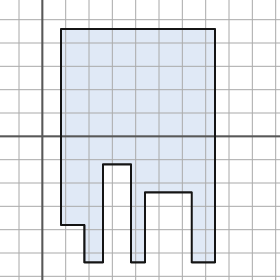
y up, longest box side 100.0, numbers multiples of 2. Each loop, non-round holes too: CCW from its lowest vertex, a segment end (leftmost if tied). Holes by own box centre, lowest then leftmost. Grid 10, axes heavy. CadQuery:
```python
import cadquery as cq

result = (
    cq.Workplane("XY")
    .moveTo(18.0, -54.0)
    .lineTo(26.0, -54.0)
    .lineTo(26.0, -12.0)
    .lineTo(38.0, -12.0)
    .lineTo(38.0, -54.0)
    .lineTo(44.0, -54.0)
    .lineTo(44.0, -24.0)
    .lineTo(64.0, -24.0)
    .lineTo(64.0, -54.0)
    .lineTo(74.0, -54.0)
    .lineTo(74.0, 46.0)
    .lineTo(8.0, 46.0)
    .lineTo(8.0, -38.0)
    .lineTo(18.0, -38.0)
    .close()
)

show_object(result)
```